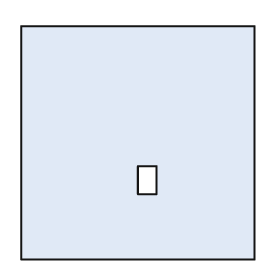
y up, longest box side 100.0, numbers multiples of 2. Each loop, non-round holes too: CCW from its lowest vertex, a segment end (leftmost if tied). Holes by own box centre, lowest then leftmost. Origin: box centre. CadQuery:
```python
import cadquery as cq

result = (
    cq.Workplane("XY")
    .moveTo(-50.0, -50.0)
    .lineTo(50.0, -50.0)
    .lineTo(50.0, 50.0)
    .lineTo(-50.0, 50.0)
    .close()
    .moveTo(0.0, -22.0)
    .lineTo(8.0, -22.0)
    .lineTo(8.0, -10.0)
    .lineTo(0.0, -10.0)
    .close()
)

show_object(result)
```